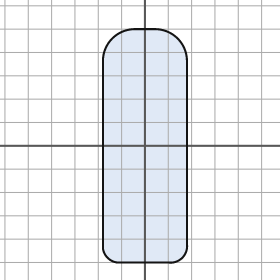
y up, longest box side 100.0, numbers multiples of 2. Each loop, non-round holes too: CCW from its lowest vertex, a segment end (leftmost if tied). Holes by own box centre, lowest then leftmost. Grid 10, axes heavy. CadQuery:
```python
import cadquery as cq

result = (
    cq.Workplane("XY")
    .moveTo(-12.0, -50.0)
    .lineTo(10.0, -50.0)
    .threePointArc((16.0, -48.0), (18.0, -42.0))
    .lineTo(18.0, 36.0)
    .threePointArc((14.0, 46.0), (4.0, 50.0))
    .lineTo(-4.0, 50.0)
    .threePointArc((-14.0, 46.0), (-18.0, 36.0))
    .lineTo(-18.0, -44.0)
    .threePointArc((-16.0, -48.0), (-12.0, -50.0))
    .close()
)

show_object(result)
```